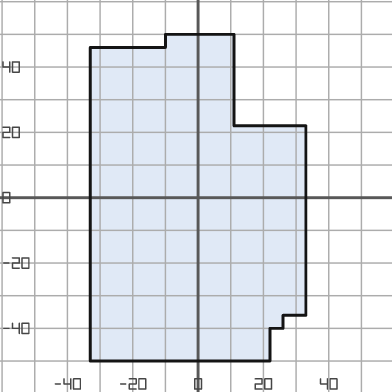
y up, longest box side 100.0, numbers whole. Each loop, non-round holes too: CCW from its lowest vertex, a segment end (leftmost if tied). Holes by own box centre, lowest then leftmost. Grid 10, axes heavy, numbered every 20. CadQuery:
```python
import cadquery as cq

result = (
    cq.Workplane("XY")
    .moveTo(-33.0, -50.0)
    .lineTo(22.0, -50.0)
    .lineTo(22.0, -40.0)
    .lineTo(26.0, -40.0)
    .lineTo(26.0, -36.0)
    .lineTo(33.0, -36.0)
    .lineTo(33.0, 22.0)
    .lineTo(11.0, 22.0)
    .lineTo(11.0, 50.0)
    .lineTo(-10.0, 50.0)
    .lineTo(-10.0, 46.0)
    .lineTo(-33.0, 46.0)
    .close()
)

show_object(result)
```